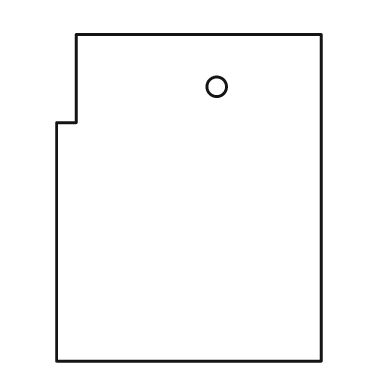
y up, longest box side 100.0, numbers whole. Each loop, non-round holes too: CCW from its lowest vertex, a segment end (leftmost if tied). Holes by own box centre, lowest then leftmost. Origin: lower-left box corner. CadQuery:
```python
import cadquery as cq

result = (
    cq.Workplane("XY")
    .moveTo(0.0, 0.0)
    .lineTo(81.0, 0.0)
    .lineTo(81.0, 100.0)
    .lineTo(6.0, 100.0)
    .lineTo(6.0, 73.0)
    .lineTo(0.0, 73.0)
    .close()
    .moveTo(49.0, 84.0)
    .circle(3.0)
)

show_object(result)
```